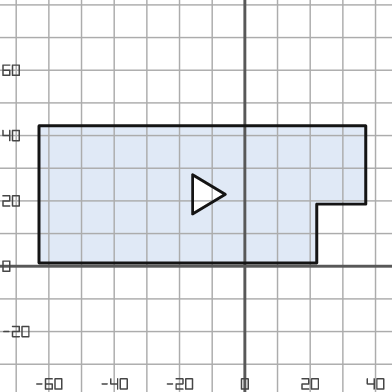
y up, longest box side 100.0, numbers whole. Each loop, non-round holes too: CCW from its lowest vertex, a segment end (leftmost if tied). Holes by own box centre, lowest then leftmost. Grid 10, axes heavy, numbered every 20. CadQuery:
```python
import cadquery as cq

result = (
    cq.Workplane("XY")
    .moveTo(-63.0, 1.0)
    .lineTo(22.0, 1.0)
    .lineTo(22.0, 19.0)
    .lineTo(37.0, 19.0)
    .lineTo(37.0, 43.0)
    .lineTo(-63.0, 43.0)
    .close()
    .moveTo(-16.0, 16.0)
    .lineTo(-6.0, 22.0)
    .lineTo(-16.0, 28.0)
    .close()
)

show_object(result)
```